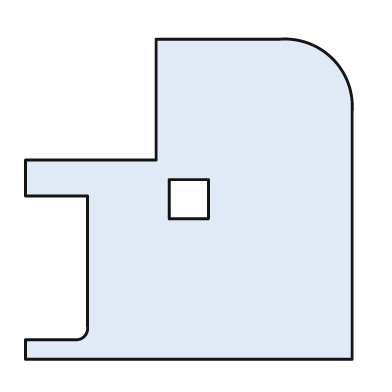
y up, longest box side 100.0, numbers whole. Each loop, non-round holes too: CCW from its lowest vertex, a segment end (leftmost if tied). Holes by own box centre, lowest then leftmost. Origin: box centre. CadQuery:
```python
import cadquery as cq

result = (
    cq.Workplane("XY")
    .moveTo(-50.0, -49.0)
    .lineTo(50.0, -49.0)
    .lineTo(50.0, 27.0)
    .threePointArc((44.0, 43.0), (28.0, 49.0))
    .lineTo(-10.0, 49.0)
    .lineTo(-10.0, 12.0)
    .lineTo(-50.0, 12.0)
    .lineTo(-50.0, 1.0)
    .lineTo(-31.0, 1.0)
    .lineTo(-31.0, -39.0)
    .threePointArc((-32.0, -42.0), (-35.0, -43.0))
    .lineTo(-50.0, -43.0)
    .close()
    .moveTo(-6.0, -6.0)
    .lineTo(6.0, -6.0)
    .lineTo(6.0, 6.0)
    .lineTo(-6.0, 6.0)
    .close()
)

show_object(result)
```